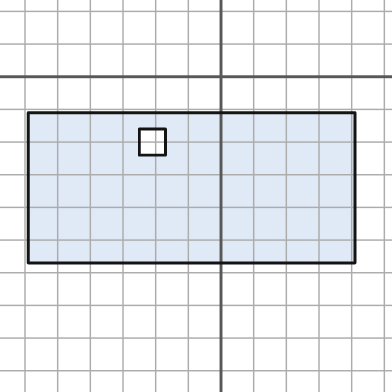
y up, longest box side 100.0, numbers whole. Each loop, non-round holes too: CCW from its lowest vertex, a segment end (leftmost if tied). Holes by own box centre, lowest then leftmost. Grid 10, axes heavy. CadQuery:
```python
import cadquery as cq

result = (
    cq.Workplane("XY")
    .moveTo(-59.0, -57.0)
    .lineTo(41.0, -57.0)
    .lineTo(41.0, -11.0)
    .lineTo(-59.0, -11.0)
    .close()
    .moveTo(-25.0, -24.0)
    .lineTo(-17.0, -24.0)
    .lineTo(-17.0, -16.0)
    .lineTo(-25.0, -16.0)
    .close()
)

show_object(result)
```